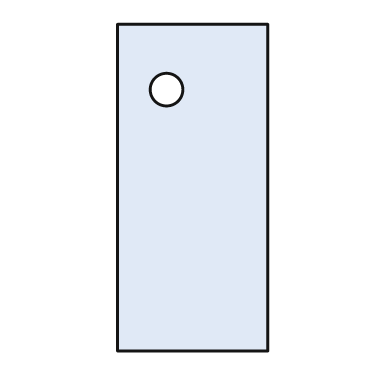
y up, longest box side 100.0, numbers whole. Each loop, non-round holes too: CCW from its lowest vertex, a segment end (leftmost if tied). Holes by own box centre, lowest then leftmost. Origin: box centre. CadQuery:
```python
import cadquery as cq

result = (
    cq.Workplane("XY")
    .moveTo(-23.0, -50.0)
    .lineTo(23.0, -50.0)
    .lineTo(23.0, 50.0)
    .lineTo(-23.0, 50.0)
    .close()
    .moveTo(-8.0, 30.0)
    .circle(5.0)
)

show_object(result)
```